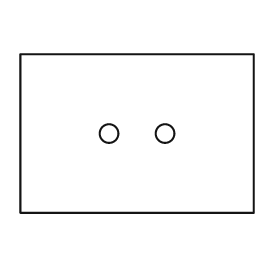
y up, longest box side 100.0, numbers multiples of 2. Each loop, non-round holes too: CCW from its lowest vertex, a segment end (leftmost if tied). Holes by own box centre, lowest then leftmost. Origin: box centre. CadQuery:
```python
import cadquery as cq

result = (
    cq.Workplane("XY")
    .moveTo(-50.0, -34.0)
    .lineTo(50.0, -34.0)
    .lineTo(50.0, 34.0)
    .lineTo(-50.0, 34.0)
    .close()
    .moveTo(-12.0, 0.0)
    .circle(4.0)
    .moveTo(12.0, 0.0)
    .circle(4.0)
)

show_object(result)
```